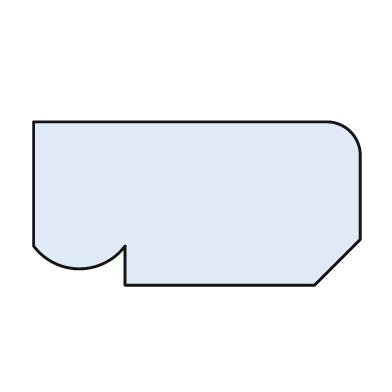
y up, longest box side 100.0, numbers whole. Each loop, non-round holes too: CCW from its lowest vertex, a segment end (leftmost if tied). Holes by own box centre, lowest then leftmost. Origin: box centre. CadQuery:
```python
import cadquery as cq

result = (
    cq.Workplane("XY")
    .moveTo(-22.0, -25.0)
    .lineTo(36.0, -25.0)
    .lineTo(50.0, -11.0)
    .lineTo(50.0, 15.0)
    .threePointArc((47.0, 22.0), (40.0, 25.0))
    .lineTo(-50.0, 25.0)
    .lineTo(-50.0, -13.0)
    .threePointArc((-36.0, -20.0), (-22.0, -13.0))
    .close()
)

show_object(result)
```